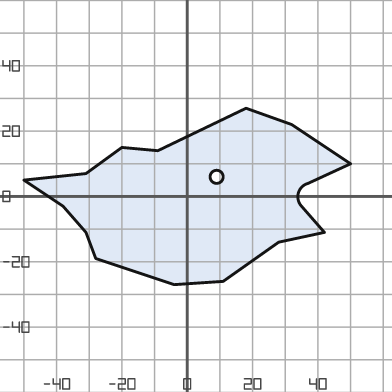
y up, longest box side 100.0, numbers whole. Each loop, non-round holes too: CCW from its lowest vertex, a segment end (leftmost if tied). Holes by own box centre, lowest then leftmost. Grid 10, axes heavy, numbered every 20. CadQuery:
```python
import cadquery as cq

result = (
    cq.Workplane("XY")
    .moveTo(-4.0, -27.0)
    .lineTo(11.0, -26.0)
    .lineTo(28.0, -14.0)
    .lineTo(42.0, -11.0)
    .lineTo(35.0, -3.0)
    .threePointArc((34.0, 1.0), (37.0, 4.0))
    .lineTo(50.0, 10.0)
    .lineTo(32.0, 22.0)
    .lineTo(18.0, 27.0)
    .lineTo(-9.0, 14.0)
    .lineTo(-20.0, 15.0)
    .lineTo(-31.0, 7.0)
    .lineTo(-50.0, 5.0)
    .lineTo(-38.0, -3.0)
    .lineTo(-31.0, -11.0)
    .lineTo(-28.0, -19.0)
    .close()
    .moveTo(9.0, 6.0)
    .circle(2.0)
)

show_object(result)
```